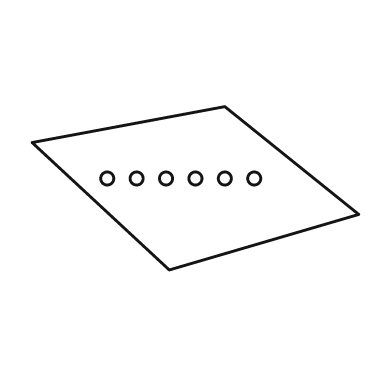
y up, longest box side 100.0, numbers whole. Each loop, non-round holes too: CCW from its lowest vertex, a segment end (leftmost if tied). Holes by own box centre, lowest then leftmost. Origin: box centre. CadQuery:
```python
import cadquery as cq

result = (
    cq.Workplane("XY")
    .moveTo(-8.0, -25.0)
    .lineTo(50.0, -8.0)
    .lineTo(9.0, 25.0)
    .lineTo(-50.0, 14.0)
    .close()
    .moveTo(-27.0, 3.0)
    .circle(2.0)
    .moveTo(-18.0, 3.0)
    .circle(2.0)
    .moveTo(-9.0, 3.0)
    .circle(2.0)
    .moveTo(0.0, 3.0)
    .circle(2.0)
    .moveTo(9.0, 3.0)
    .circle(2.0)
    .moveTo(18.0, 3.0)
    .circle(2.0)
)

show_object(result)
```